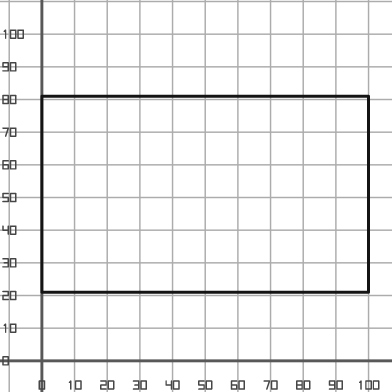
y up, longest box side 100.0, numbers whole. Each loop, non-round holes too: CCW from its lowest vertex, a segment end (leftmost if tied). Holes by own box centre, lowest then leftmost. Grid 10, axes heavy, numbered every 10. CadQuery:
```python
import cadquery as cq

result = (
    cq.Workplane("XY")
    .moveTo(0.0, 21.0)
    .lineTo(100.0, 21.0)
    .lineTo(100.0, 81.0)
    .lineTo(0.0, 81.0)
    .close()
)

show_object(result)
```